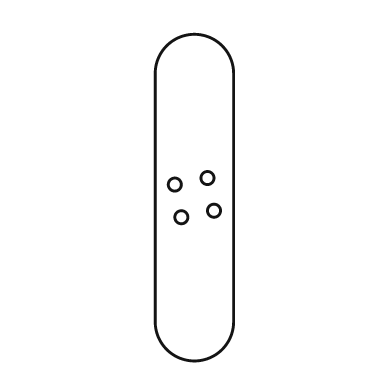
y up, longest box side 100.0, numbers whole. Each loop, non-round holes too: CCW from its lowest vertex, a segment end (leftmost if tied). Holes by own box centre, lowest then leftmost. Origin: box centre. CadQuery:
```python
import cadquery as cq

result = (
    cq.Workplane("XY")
    .moveTo(-12.0, -38.0)
    .threePointArc((0.0, -50.0), (12.0, -38.0))
    .lineTo(12.0, 38.0)
    .threePointArc((0.0, 50.0), (-12.0, 38.0))
    .close()
    .moveTo(-4.0, -6.0)
    .circle(2.0)
    .moveTo(6.0, -4.0)
    .circle(2.0)
    .moveTo(-6.0, 4.0)
    .circle(2.0)
    .moveTo(4.0, 6.0)
    .circle(2.0)
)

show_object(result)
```